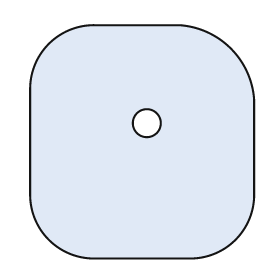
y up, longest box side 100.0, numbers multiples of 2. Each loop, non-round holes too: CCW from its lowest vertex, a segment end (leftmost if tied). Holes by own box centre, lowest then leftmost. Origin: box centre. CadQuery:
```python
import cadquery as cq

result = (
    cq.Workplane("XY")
    .moveTo(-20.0, -50.0)
    .lineTo(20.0, -50.0)
    .threePointArc((40.0, -42.0), (48.0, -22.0))
    .lineTo(48.0, 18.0)
    .threePointArc((38.0, 40.0), (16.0, 50.0))
    .lineTo(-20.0, 50.0)
    .threePointArc((-40.0, 42.0), (-48.0, 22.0))
    .lineTo(-48.0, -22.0)
    .threePointArc((-40.0, -42.0), (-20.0, -50.0))
    .close()
    .moveTo(2.0, 8.0)
    .circle(6.0)
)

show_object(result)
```